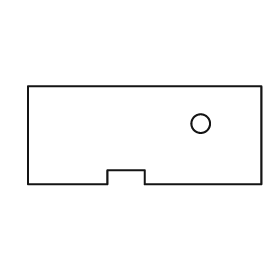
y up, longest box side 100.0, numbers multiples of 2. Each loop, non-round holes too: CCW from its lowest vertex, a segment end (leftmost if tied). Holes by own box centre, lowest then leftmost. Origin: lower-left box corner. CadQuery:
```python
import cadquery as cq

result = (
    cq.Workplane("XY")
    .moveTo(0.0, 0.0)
    .lineTo(34.0, 0.0)
    .lineTo(34.0, 6.0)
    .lineTo(50.0, 6.0)
    .lineTo(50.0, 0.0)
    .lineTo(100.0, 0.0)
    .lineTo(100.0, 42.0)
    .lineTo(0.0, 42.0)
    .close()
    .moveTo(74.0, 26.0)
    .circle(4.0)
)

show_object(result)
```